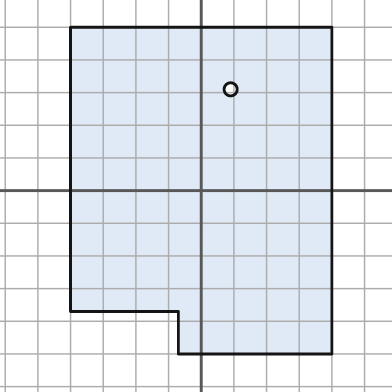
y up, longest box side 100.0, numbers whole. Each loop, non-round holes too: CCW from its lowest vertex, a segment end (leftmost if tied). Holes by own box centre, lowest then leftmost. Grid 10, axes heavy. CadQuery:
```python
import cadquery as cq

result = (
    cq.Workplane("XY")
    .moveTo(-7.0, -50.0)
    .lineTo(40.0, -50.0)
    .lineTo(40.0, 50.0)
    .lineTo(-40.0, 50.0)
    .lineTo(-40.0, -37.0)
    .lineTo(-7.0, -37.0)
    .close()
    .moveTo(9.0, 31.0)
    .circle(2.0)
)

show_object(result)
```